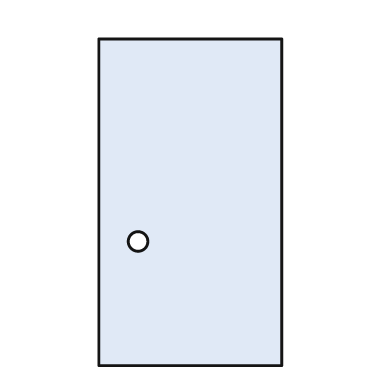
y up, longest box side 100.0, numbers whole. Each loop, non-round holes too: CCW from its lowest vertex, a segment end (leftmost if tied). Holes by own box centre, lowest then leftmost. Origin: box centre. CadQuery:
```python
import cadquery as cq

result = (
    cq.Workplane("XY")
    .moveTo(-28.0, -50.0)
    .lineTo(28.0, -50.0)
    .lineTo(28.0, 50.0)
    .lineTo(-28.0, 50.0)
    .close()
    .moveTo(-16.0, -12.0)
    .circle(3.0)
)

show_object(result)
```